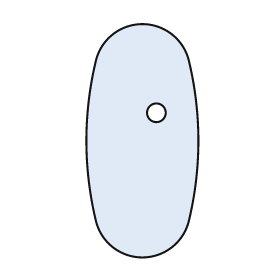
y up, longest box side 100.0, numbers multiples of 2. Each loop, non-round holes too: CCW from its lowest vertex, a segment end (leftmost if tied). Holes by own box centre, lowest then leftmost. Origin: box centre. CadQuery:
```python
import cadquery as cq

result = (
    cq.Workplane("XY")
    .moveTo(-20.0, -34.0)
    .threePointArc((0.0, -50.0), (20.0, -34.0))
    .threePointArc((24.0, 0.0), (20.0, 34.0))
    .threePointArc((0.0, 50.0), (-20.0, 34.0))
    .threePointArc((-24.0, 0.0), (-20.0, -34.0))
    .close()
    .moveTo(6.0, 12.0)
    .circle(4.0)
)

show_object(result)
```